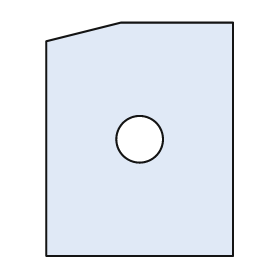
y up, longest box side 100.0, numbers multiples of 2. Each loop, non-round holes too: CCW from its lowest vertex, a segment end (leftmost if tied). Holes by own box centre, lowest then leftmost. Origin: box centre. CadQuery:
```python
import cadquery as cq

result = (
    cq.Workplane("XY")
    .moveTo(-40.0, -50.0)
    .lineTo(40.0, -50.0)
    .lineTo(40.0, 50.0)
    .lineTo(-8.0, 50.0)
    .lineTo(-40.0, 42.0)
    .close()
    .moveTo(0.0, 0.0)
    .circle(10.0)
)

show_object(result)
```